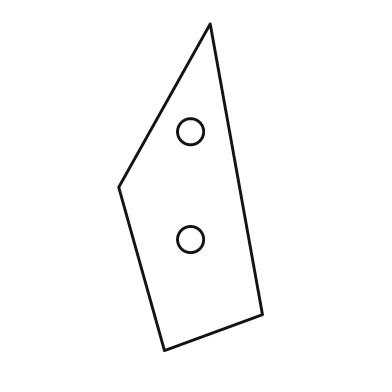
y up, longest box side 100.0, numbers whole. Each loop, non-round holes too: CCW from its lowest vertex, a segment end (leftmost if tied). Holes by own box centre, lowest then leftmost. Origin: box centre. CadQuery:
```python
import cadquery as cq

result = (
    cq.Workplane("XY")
    .moveTo(-8.0, -50.0)
    .lineTo(22.0, -39.0)
    .lineTo(6.0, 50.0)
    .lineTo(-22.0, 0.0)
    .close()
    .moveTo(0.0, -16.0)
    .circle(4.0)
    .moveTo(0.0, 17.0)
    .circle(4.0)
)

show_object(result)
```